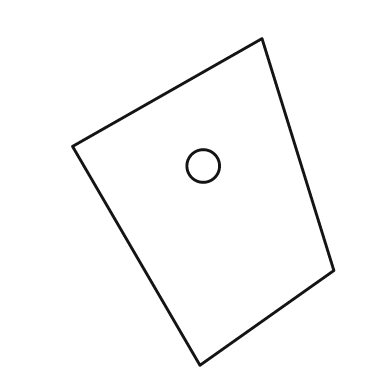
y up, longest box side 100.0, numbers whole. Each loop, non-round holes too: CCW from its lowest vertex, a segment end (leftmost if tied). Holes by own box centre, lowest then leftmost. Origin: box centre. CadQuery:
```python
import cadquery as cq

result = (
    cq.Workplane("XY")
    .moveTo(-1.0, -50.0)
    .lineTo(40.0, -21.0)
    .lineTo(18.0, 50.0)
    .lineTo(-40.0, 17.0)
    .close()
    .moveTo(0.0, 11.0)
    .circle(5.0)
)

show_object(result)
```